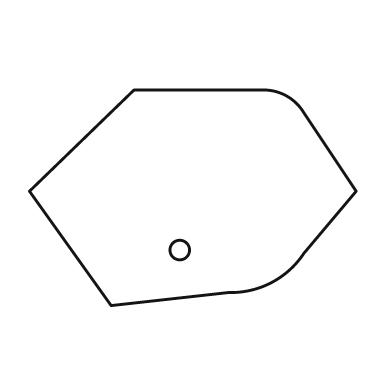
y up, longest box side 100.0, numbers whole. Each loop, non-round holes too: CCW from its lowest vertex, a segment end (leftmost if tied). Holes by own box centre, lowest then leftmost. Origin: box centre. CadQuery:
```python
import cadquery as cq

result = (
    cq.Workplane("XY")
    .moveTo(-25.0, -33.0)
    .lineTo(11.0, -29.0)
    .threePointArc((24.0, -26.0), (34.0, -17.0))
    .lineTo(50.0, 2.0)
    .lineTo(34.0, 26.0)
    .threePointArc((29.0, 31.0), (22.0, 33.0))
    .lineTo(-18.0, 33.0)
    .lineTo(-50.0, 2.0)
    .close()
    .moveTo(-4.0, -16.0)
    .circle(3.0)
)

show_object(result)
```